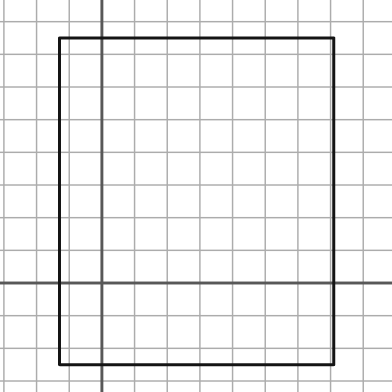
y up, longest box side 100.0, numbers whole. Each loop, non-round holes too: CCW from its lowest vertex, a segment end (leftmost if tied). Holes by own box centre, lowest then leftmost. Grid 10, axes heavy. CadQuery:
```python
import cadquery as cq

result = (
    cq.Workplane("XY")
    .moveTo(-13.0, -25.0)
    .lineTo(71.0, -25.0)
    .lineTo(71.0, 75.0)
    .lineTo(-13.0, 75.0)
    .close()
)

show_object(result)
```